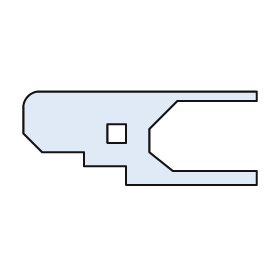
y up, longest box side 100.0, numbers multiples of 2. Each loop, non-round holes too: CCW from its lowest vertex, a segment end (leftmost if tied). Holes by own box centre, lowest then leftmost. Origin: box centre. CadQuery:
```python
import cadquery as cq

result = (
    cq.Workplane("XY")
    .moveTo(-6.0, -20.0)
    .lineTo(50.0, -20.0)
    .lineTo(50.0, -14.0)
    .lineTo(14.0, -14.0)
    .lineTo(4.0, -6.0)
    .lineTo(4.0, 4.0)
    .lineTo(16.0, 16.0)
    .lineTo(50.0, 16.0)
    .lineTo(50.0, 20.0)
    .lineTo(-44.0, 20.0)
    .threePointArc((-48.0, 18.0), (-50.0, 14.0))
    .lineTo(-50.0, 2.0)
    .lineTo(-42.0, -6.0)
    .lineTo(-24.0, -6.0)
    .lineTo(-24.0, -12.0)
    .lineTo(-6.0, -12.0)
    .close()
    .moveTo(-14.0, -2.0)
    .lineTo(-6.0, -2.0)
    .lineTo(-6.0, 6.0)
    .lineTo(-14.0, 6.0)
    .close()
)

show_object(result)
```